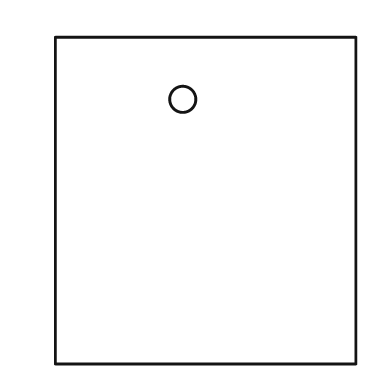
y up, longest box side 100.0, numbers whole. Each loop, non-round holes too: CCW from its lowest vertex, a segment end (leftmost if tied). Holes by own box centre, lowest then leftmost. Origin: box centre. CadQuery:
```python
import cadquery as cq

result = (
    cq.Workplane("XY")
    .moveTo(-46.0, -50.0)
    .lineTo(46.0, -50.0)
    .lineTo(46.0, 50.0)
    .lineTo(-46.0, 50.0)
    .close()
    .moveTo(-7.0, 31.0)
    .circle(4.0)
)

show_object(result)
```